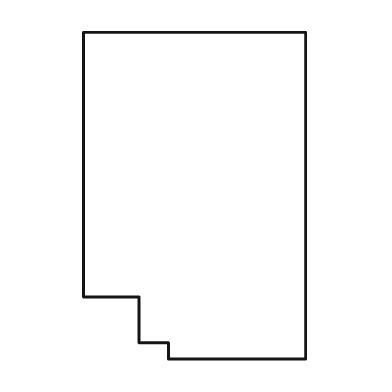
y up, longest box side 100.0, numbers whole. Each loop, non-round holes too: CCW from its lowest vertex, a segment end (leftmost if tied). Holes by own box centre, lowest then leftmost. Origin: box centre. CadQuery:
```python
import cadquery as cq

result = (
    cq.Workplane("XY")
    .moveTo(-8.0, -50.0)
    .lineTo(34.0, -50.0)
    .lineTo(34.0, 50.0)
    .lineTo(-34.0, 50.0)
    .lineTo(-34.0, -31.0)
    .lineTo(-17.0, -31.0)
    .lineTo(-17.0, -45.0)
    .lineTo(-8.0, -45.0)
    .close()
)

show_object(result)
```